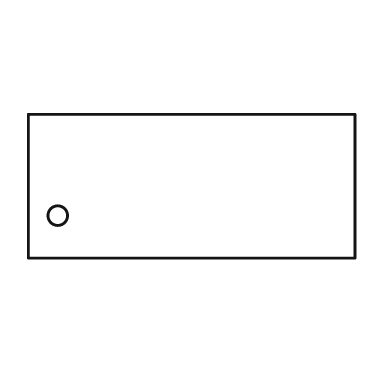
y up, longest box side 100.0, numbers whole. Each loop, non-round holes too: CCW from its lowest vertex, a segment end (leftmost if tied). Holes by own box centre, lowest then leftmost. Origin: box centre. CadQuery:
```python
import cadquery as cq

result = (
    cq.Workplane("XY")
    .moveTo(-50.0, -22.0)
    .lineTo(50.0, -22.0)
    .lineTo(50.0, 22.0)
    .lineTo(-50.0, 22.0)
    .close()
    .moveTo(-41.0, -9.0)
    .circle(3.0)
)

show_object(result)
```